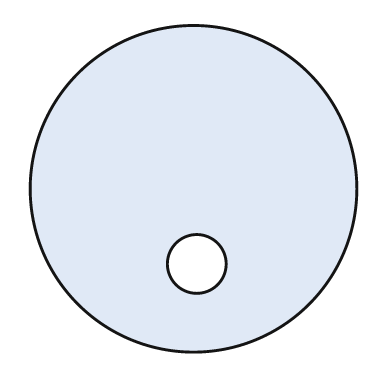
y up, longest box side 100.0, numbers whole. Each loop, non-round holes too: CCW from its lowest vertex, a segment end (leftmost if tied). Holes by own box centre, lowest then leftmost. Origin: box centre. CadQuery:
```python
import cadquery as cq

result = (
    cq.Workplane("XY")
    .moveTo(0.0, 0.0)
    .circle(50.0)
    .moveTo(1.0, -23.0)
    .circle(9.0)
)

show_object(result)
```